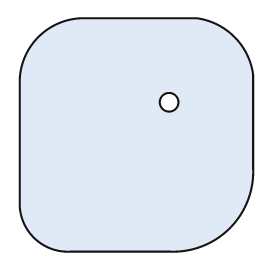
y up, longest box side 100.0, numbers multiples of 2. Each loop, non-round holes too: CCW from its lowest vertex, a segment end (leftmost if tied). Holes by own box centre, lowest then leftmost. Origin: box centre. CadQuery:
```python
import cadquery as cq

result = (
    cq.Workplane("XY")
    .moveTo(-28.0, -50.0)
    .lineTo(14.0, -50.0)
    .threePointArc((40.0, -40.0), (50.0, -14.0))
    .lineTo(50.0, 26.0)
    .threePointArc((42.0, 42.0), (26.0, 50.0))
    .lineTo(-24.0, 50.0)
    .threePointArc((-42.0, 42.0), (-50.0, 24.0))
    .lineTo(-50.0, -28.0)
    .threePointArc((-44.0, -44.0), (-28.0, -50.0))
    .close()
    .moveTo(14.0, 14.0)
    .circle(4.0)
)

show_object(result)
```